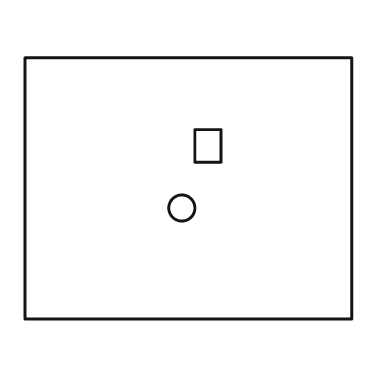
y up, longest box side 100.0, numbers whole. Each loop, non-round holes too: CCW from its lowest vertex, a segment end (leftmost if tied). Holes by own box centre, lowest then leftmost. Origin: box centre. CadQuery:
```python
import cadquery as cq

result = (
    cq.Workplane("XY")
    .moveTo(-50.0, -40.0)
    .lineTo(50.0, -40.0)
    .lineTo(50.0, 40.0)
    .lineTo(-50.0, 40.0)
    .close()
    .moveTo(-2.0, -6.0)
    .circle(4.0)
    .moveTo(2.0, 8.0)
    .lineTo(10.0, 8.0)
    .lineTo(10.0, 18.0)
    .lineTo(2.0, 18.0)
    .close()
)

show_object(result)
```